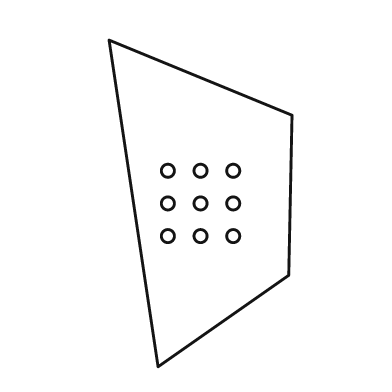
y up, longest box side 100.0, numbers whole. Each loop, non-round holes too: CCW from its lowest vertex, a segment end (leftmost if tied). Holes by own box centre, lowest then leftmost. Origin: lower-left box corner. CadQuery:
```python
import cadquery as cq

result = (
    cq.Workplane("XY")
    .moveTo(15.0, 0.0)
    .lineTo(55.0, 28.0)
    .lineTo(56.0, 77.0)
    .lineTo(0.0, 100.0)
    .close()
    .moveTo(18.0, 40.0)
    .circle(2.0)
    .moveTo(28.0, 40.0)
    .circle(2.0)
    .moveTo(38.0, 40.0)
    .circle(2.0)
    .moveTo(18.0, 50.0)
    .circle(2.0)
    .moveTo(28.0, 50.0)
    .circle(2.0)
    .moveTo(38.0, 50.0)
    .circle(2.0)
    .moveTo(18.0, 60.0)
    .circle(2.0)
    .moveTo(28.0, 60.0)
    .circle(2.0)
    .moveTo(38.0, 60.0)
    .circle(2.0)
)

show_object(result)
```